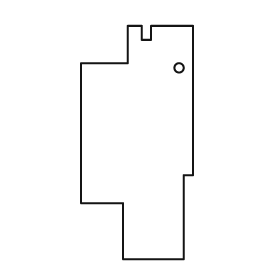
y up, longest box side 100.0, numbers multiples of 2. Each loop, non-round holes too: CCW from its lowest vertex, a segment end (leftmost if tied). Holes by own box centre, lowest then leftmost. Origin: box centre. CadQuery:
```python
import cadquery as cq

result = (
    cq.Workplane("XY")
    .moveTo(-6.0, -50.0)
    .lineTo(20.0, -50.0)
    .lineTo(20.0, -14.0)
    .lineTo(24.0, -14.0)
    .lineTo(24.0, 50.0)
    .lineTo(6.0, 50.0)
    .lineTo(6.0, 44.0)
    .lineTo(2.0, 44.0)
    .lineTo(2.0, 50.0)
    .lineTo(-4.0, 50.0)
    .lineTo(-4.0, 34.0)
    .lineTo(-24.0, 34.0)
    .lineTo(-24.0, -26.0)
    .lineTo(-6.0, -26.0)
    .close()
    .moveTo(18.0, 32.0)
    .circle(2.0)
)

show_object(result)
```